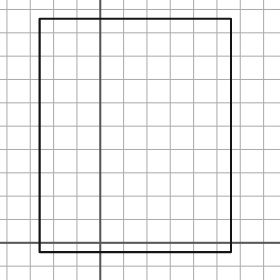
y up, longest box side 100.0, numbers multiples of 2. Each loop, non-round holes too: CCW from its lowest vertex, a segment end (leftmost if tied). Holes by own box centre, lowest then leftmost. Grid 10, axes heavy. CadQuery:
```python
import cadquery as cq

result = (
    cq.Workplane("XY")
    .moveTo(-26.0, -4.0)
    .lineTo(56.0, -4.0)
    .lineTo(56.0, 96.0)
    .lineTo(-26.0, 96.0)
    .close()
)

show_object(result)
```